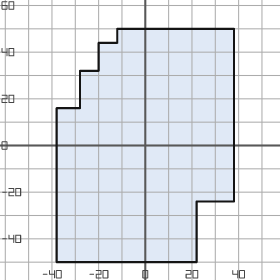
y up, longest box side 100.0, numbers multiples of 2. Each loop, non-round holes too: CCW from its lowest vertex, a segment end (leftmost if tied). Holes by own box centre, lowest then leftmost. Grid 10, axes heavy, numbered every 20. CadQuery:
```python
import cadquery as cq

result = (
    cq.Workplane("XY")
    .moveTo(-38.0, -50.0)
    .lineTo(22.0, -50.0)
    .lineTo(22.0, -24.0)
    .lineTo(38.0, -24.0)
    .lineTo(38.0, 50.0)
    .lineTo(-12.0, 50.0)
    .lineTo(-12.0, 44.0)
    .lineTo(-20.0, 44.0)
    .lineTo(-20.0, 32.0)
    .lineTo(-28.0, 32.0)
    .lineTo(-28.0, 16.0)
    .lineTo(-38.0, 16.0)
    .close()
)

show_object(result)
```